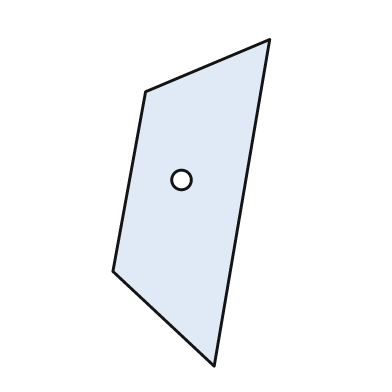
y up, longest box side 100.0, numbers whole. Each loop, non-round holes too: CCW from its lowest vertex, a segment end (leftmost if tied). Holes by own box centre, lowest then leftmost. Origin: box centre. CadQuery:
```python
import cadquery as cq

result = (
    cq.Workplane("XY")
    .moveTo(7.0, -50.0)
    .lineTo(24.0, 50.0)
    .lineTo(-14.0, 34.0)
    .lineTo(-24.0, -21.0)
    .close()
    .moveTo(-3.0, 7.0)
    .circle(3.0)
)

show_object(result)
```